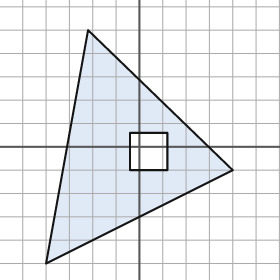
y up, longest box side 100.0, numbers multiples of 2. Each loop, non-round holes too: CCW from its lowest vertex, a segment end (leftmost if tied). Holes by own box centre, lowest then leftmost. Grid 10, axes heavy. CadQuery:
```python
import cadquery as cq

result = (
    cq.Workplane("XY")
    .moveTo(-40.0, -50.0)
    .lineTo(40.0, -10.0)
    .lineTo(-22.0, 50.0)
    .close()
    .moveTo(-4.0, -10.0)
    .lineTo(12.0, -10.0)
    .lineTo(12.0, 6.0)
    .lineTo(-4.0, 6.0)
    .close()
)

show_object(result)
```